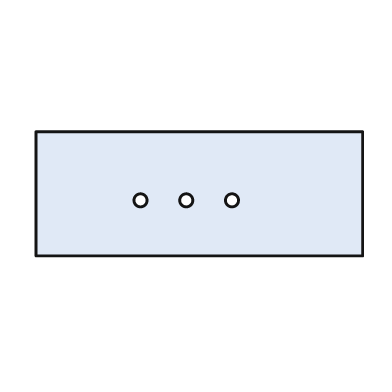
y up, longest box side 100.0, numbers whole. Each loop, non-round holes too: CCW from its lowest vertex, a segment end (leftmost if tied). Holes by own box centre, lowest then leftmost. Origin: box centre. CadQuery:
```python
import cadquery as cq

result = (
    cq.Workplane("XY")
    .moveTo(-50.0, -19.0)
    .lineTo(50.0, -19.0)
    .lineTo(50.0, 19.0)
    .lineTo(-50.0, 19.0)
    .close()
    .moveTo(-18.0, -2.0)
    .circle(2.0)
    .moveTo(-4.0, -2.0)
    .circle(2.0)
    .moveTo(10.0, -2.0)
    .circle(2.0)
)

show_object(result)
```